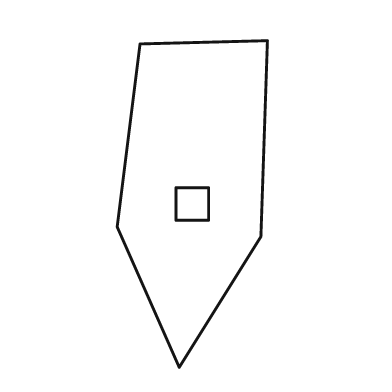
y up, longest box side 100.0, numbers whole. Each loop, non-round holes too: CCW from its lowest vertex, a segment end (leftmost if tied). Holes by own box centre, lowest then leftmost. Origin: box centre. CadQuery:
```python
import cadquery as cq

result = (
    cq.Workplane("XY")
    .moveTo(-4.0, -50.0)
    .lineTo(21.0, -10.0)
    .lineTo(23.0, 50.0)
    .lineTo(-16.0, 49.0)
    .lineTo(-23.0, -7.0)
    .close()
    .moveTo(-5.0, -5.0)
    .lineTo(5.0, -5.0)
    .lineTo(5.0, 5.0)
    .lineTo(-5.0, 5.0)
    .close()
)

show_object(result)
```